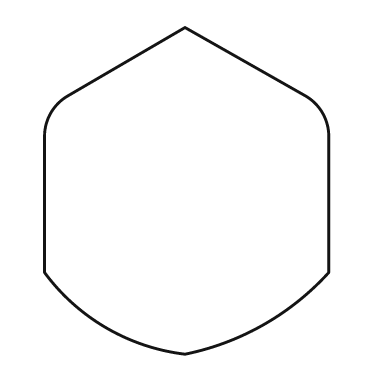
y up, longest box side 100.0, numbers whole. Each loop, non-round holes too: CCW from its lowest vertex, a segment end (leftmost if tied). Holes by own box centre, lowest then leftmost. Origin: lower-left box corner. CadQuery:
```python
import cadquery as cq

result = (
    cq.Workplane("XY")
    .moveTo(43.0, 0.0)
    .threePointArc((67.0, 9.0), (87.0, 25.0))
    .lineTo(87.0, 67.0)
    .threePointArc((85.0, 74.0), (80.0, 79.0))
    .lineTo(43.0, 100.0)
    .lineTo(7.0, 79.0)
    .threePointArc((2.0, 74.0), (0.0, 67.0))
    .lineTo(0.0, 25.0)
    .threePointArc((19.0, 8.0), (43.0, 0.0))
    .close()
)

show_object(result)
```